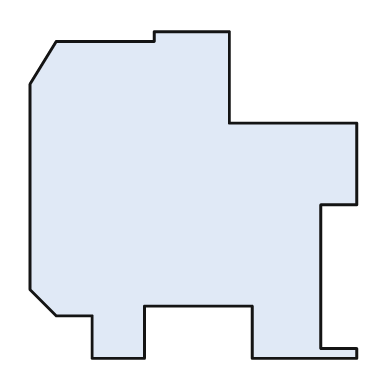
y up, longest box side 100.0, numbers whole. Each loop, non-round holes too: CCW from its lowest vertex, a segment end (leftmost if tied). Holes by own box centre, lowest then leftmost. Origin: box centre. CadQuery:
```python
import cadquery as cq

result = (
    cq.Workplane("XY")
    .moveTo(-31.0, -50.0)
    .lineTo(-15.0, -50.0)
    .lineTo(-15.0, -34.0)
    .lineTo(18.0, -34.0)
    .lineTo(18.0, -50.0)
    .lineTo(50.0, -50.0)
    .lineTo(50.0, -47.0)
    .lineTo(39.0, -47.0)
    .lineTo(39.0, -3.0)
    .lineTo(50.0, -3.0)
    .lineTo(50.0, 22.0)
    .lineTo(11.0, 22.0)
    .lineTo(11.0, 50.0)
    .lineTo(-12.0, 50.0)
    .lineTo(-12.0, 47.0)
    .lineTo(-42.0, 47.0)
    .lineTo(-50.0, 34.0)
    .lineTo(-50.0, -29.0)
    .lineTo(-42.0, -37.0)
    .lineTo(-31.0, -37.0)
    .close()
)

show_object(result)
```